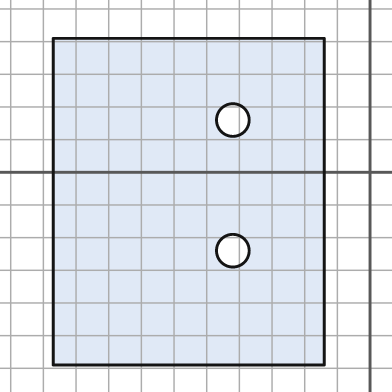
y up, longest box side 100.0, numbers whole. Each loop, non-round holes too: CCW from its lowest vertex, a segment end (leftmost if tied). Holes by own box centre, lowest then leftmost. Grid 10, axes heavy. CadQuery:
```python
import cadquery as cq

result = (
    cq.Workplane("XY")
    .moveTo(-97.0, -59.0)
    .lineTo(-14.0, -59.0)
    .lineTo(-14.0, 41.0)
    .lineTo(-97.0, 41.0)
    .close()
    .moveTo(-42.0, -24.0)
    .circle(5.0)
    .moveTo(-42.0, 16.0)
    .circle(5.0)
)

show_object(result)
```